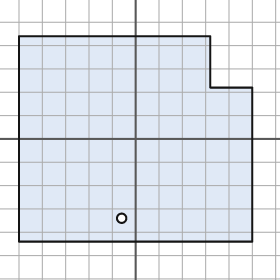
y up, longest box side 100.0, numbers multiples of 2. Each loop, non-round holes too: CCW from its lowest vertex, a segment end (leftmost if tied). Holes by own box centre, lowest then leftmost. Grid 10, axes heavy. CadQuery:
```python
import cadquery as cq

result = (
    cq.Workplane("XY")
    .moveTo(-50.0, -44.0)
    .lineTo(50.0, -44.0)
    .lineTo(50.0, 22.0)
    .lineTo(32.0, 22.0)
    .lineTo(32.0, 44.0)
    .lineTo(-50.0, 44.0)
    .close()
    .moveTo(-6.0, -34.0)
    .circle(2.0)
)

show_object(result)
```